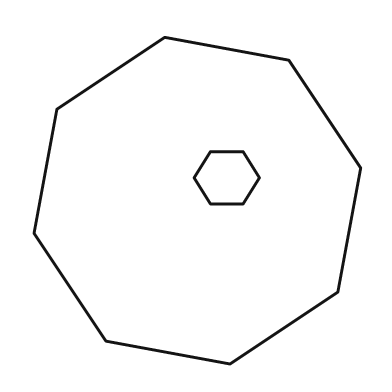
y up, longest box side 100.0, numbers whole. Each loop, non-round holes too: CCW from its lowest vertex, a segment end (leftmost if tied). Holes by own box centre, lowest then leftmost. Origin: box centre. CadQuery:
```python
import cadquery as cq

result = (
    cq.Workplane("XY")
    .moveTo(10.0, -50.0)
    .lineTo(43.0, -28.0)
    .lineTo(50.0, 10.0)
    .lineTo(28.0, 43.0)
    .lineTo(-10.0, 50.0)
    .lineTo(-43.0, 28.0)
    .lineTo(-50.0, -10.0)
    .lineTo(-28.0, -43.0)
    .close()
    .moveTo(4.0, -1.0)
    .lineTo(14.0, -1.0)
    .lineTo(19.0, 7.0)
    .lineTo(14.0, 15.0)
    .lineTo(4.0, 15.0)
    .lineTo(-1.0, 7.0)
    .close()
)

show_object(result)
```